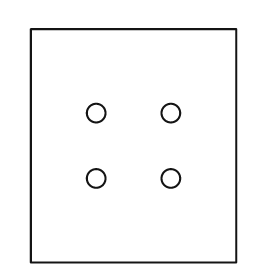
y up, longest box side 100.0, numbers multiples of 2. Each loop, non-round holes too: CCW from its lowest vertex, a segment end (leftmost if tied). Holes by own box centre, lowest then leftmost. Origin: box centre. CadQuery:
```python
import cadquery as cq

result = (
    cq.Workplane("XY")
    .moveTo(-44.0, -50.0)
    .lineTo(44.0, -50.0)
    .lineTo(44.0, 50.0)
    .lineTo(-44.0, 50.0)
    .close()
    .moveTo(-16.0, -14.0)
    .circle(4.0)
    .moveTo(16.0, -14.0)
    .circle(4.0)
    .moveTo(-16.0, 14.0)
    .circle(4.0)
    .moveTo(16.0, 14.0)
    .circle(4.0)
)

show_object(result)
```